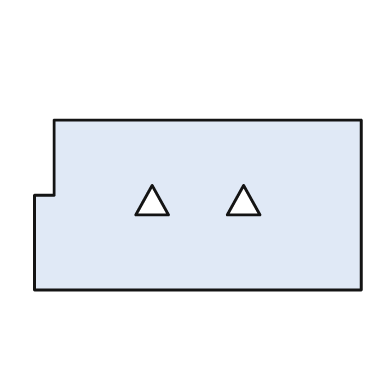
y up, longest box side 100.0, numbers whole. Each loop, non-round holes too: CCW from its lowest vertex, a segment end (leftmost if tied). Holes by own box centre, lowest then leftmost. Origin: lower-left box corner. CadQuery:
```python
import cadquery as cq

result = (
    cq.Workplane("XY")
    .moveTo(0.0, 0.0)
    .lineTo(100.0, 0.0)
    .lineTo(100.0, 52.0)
    .lineTo(6.0, 52.0)
    .lineTo(6.0, 29.0)
    .lineTo(0.0, 29.0)
    .close()
    .moveTo(31.0, 23.0)
    .lineTo(41.0, 23.0)
    .lineTo(36.0, 32.0)
    .close()
    .moveTo(59.0, 23.0)
    .lineTo(69.0, 23.0)
    .lineTo(64.0, 32.0)
    .close()
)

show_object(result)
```